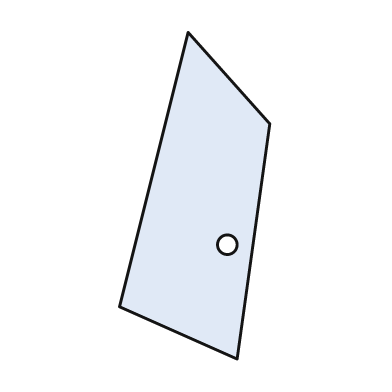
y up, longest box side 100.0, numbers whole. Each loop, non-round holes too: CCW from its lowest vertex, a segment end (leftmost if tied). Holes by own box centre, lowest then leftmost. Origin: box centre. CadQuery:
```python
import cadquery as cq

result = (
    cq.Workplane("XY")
    .moveTo(13.0, -50.0)
    .lineTo(23.0, 22.0)
    .lineTo(-2.0, 50.0)
    .lineTo(-23.0, -34.0)
    .close()
    .moveTo(10.0, -15.0)
    .circle(3.0)
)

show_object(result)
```